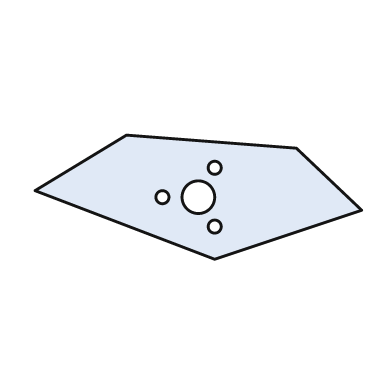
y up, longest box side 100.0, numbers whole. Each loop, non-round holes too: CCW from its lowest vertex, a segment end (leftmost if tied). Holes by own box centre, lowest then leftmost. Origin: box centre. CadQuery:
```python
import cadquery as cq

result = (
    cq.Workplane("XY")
    .moveTo(5.0, -19.0)
    .lineTo(50.0, -4.0)
    .lineTo(30.0, 15.0)
    .lineTo(-22.0, 19.0)
    .lineTo(-50.0, 2.0)
    .close()
    .moveTo(5.0, -9.0)
    .circle(2.0)
    .moveTo(-11.0, 0.0)
    .circle(2.0)
    .moveTo(0.0, 0.0)
    .circle(5.0)
    .moveTo(5.0, 9.0)
    .circle(2.0)
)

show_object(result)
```